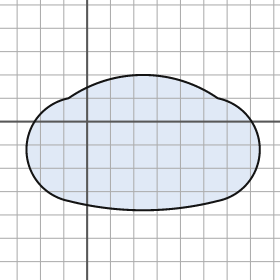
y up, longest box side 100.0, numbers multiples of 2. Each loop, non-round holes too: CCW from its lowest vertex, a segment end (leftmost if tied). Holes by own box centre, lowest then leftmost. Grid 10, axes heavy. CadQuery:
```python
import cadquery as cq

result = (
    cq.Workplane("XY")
    .moveTo(-8.0, -34.0)
    .threePointArc((24.0, -38.0), (56.0, -34.0))
    .threePointArc((74.0, -12.0), (56.0, 10.0))
    .threePointArc((24.0, 20.0), (-8.0, 10.0))
    .threePointArc((-26.0, -12.0), (-8.0, -34.0))
    .close()
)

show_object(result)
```